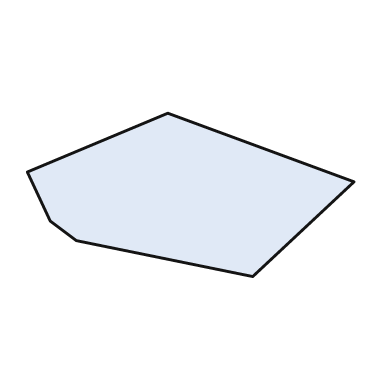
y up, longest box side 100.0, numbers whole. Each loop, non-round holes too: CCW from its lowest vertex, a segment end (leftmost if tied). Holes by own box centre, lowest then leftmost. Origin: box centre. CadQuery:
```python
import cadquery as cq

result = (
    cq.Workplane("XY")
    .moveTo(19.0, -25.0)
    .lineTo(50.0, 4.0)
    .lineTo(-7.0, 25.0)
    .lineTo(-50.0, 7.0)
    .lineTo(-43.0, -8.0)
    .lineTo(-35.0, -14.0)
    .close()
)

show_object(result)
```